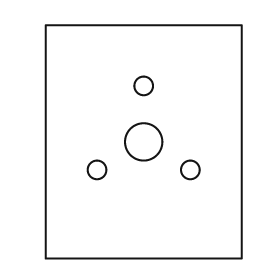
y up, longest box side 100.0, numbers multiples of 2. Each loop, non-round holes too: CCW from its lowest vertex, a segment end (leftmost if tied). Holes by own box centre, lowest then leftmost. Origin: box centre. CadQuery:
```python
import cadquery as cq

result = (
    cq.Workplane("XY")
    .moveTo(-42.0, -50.0)
    .lineTo(42.0, -50.0)
    .lineTo(42.0, 50.0)
    .lineTo(-42.0, 50.0)
    .close()
    .moveTo(-20.0, -12.0)
    .circle(4.0)
    .moveTo(20.0, -12.0)
    .circle(4.0)
    .moveTo(0.0, 0.0)
    .circle(8.0)
    .moveTo(0.0, 24.0)
    .circle(4.0)
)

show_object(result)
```